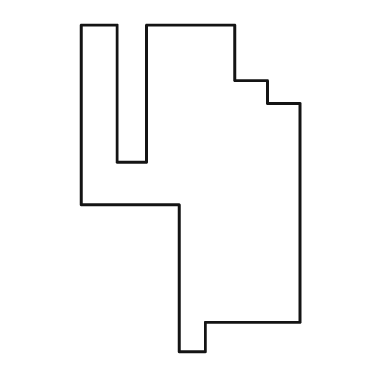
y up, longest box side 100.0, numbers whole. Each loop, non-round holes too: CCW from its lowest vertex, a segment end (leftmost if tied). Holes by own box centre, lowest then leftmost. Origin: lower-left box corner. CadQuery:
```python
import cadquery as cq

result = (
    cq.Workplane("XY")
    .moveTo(30.0, 0.0)
    .lineTo(38.0, 0.0)
    .lineTo(38.0, 9.0)
    .lineTo(67.0, 9.0)
    .lineTo(67.0, 76.0)
    .lineTo(57.0, 76.0)
    .lineTo(57.0, 83.0)
    .lineTo(47.0, 83.0)
    .lineTo(47.0, 100.0)
    .lineTo(20.0, 100.0)
    .lineTo(20.0, 58.0)
    .lineTo(11.0, 58.0)
    .lineTo(11.0, 100.0)
    .lineTo(0.0, 100.0)
    .lineTo(0.0, 45.0)
    .lineTo(30.0, 45.0)
    .close()
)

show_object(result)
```